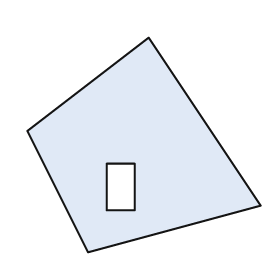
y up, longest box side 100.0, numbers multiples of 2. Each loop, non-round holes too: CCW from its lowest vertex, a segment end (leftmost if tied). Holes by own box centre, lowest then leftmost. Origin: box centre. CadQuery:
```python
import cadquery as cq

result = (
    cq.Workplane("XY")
    .moveTo(-24.0, -46.0)
    .lineTo(50.0, -26.0)
    .lineTo(2.0, 46.0)
    .lineTo(-50.0, 6.0)
    .close()
    .moveTo(-16.0, -28.0)
    .lineTo(-4.0, -28.0)
    .lineTo(-4.0, -8.0)
    .lineTo(-16.0, -8.0)
    .close()
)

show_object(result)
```